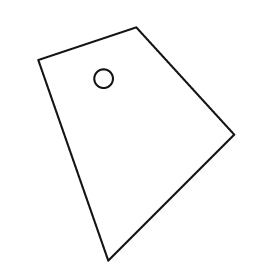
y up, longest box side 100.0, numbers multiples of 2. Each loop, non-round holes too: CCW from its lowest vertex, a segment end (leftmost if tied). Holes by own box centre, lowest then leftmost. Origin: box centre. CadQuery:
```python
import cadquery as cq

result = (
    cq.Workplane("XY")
    .moveTo(-12.0, -50.0)
    .lineTo(42.0, 4.0)
    .lineTo(0.0, 50.0)
    .lineTo(-42.0, 36.0)
    .close()
    .moveTo(-14.0, 28.0)
    .circle(4.0)
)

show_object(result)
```